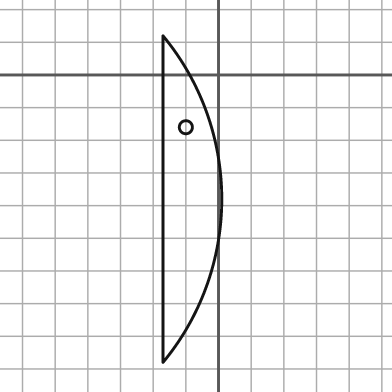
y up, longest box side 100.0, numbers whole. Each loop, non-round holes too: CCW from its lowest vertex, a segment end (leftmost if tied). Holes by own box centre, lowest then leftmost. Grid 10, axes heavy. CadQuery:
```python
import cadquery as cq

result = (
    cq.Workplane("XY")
    .moveTo(-17.0, -88.0)
    .threePointArc((1.0, -38.0), (-17.0, 12.0))
    .close()
    .moveTo(-10.0, -16.0)
    .circle(2.0)
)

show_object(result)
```